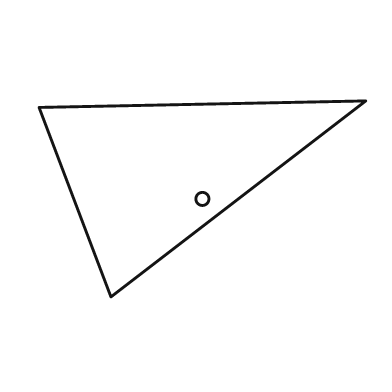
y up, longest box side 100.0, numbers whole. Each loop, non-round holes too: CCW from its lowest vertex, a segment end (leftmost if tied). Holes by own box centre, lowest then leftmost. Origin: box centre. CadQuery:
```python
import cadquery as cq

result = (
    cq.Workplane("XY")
    .moveTo(-28.0, -30.0)
    .lineTo(50.0, 30.0)
    .lineTo(-50.0, 28.0)
    .close()
    .moveTo(0.0, 0.0)
    .circle(2.0)
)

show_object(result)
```